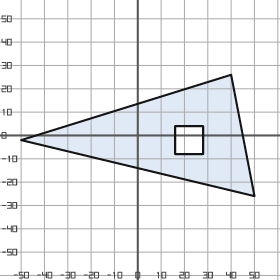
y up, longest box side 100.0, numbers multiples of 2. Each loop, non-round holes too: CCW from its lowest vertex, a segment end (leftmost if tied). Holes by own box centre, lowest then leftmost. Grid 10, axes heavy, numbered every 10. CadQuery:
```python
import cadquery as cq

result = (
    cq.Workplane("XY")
    .moveTo(50.0, -26.0)
    .lineTo(40.0, 26.0)
    .lineTo(-50.0, -2.0)
    .close()
    .moveTo(16.0, -8.0)
    .lineTo(28.0, -8.0)
    .lineTo(28.0, 4.0)
    .lineTo(16.0, 4.0)
    .close()
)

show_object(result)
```